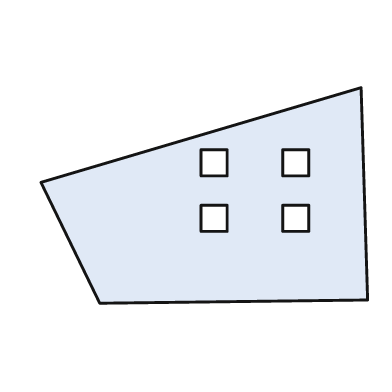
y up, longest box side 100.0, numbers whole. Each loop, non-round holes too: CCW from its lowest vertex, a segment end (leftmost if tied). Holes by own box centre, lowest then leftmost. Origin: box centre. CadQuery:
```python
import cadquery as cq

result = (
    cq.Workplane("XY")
    .moveTo(-32.0, -33.0)
    .lineTo(50.0, -32.0)
    .lineTo(48.0, 33.0)
    .lineTo(-50.0, 4.0)
    .close()
    .moveTo(-1.0, -11.0)
    .lineTo(7.0, -11.0)
    .lineTo(7.0, -3.0)
    .lineTo(-1.0, -3.0)
    .close()
    .moveTo(24.0, -11.0)
    .lineTo(32.0, -11.0)
    .lineTo(32.0, -3.0)
    .lineTo(24.0, -3.0)
    .close()
    .moveTo(-1.0, 6.0)
    .lineTo(7.0, 6.0)
    .lineTo(7.0, 14.0)
    .lineTo(-1.0, 14.0)
    .close()
    .moveTo(24.0, 6.0)
    .lineTo(32.0, 6.0)
    .lineTo(32.0, 14.0)
    .lineTo(24.0, 14.0)
    .close()
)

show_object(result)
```